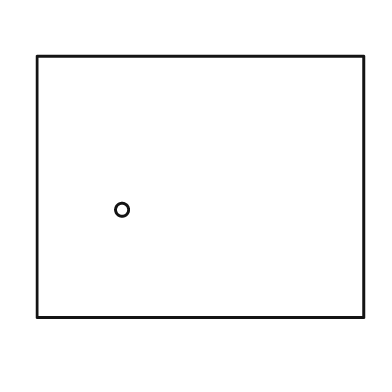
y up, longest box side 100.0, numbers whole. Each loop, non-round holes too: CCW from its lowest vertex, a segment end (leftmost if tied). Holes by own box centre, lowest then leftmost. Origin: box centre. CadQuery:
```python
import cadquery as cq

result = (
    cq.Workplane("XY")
    .moveTo(-50.0, -40.0)
    .lineTo(50.0, -40.0)
    .lineTo(50.0, 40.0)
    .lineTo(-50.0, 40.0)
    .close()
    .moveTo(-24.0, -7.0)
    .circle(2.0)
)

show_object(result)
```